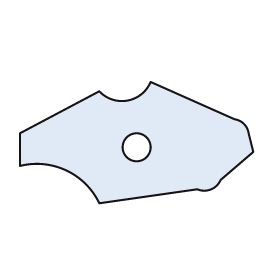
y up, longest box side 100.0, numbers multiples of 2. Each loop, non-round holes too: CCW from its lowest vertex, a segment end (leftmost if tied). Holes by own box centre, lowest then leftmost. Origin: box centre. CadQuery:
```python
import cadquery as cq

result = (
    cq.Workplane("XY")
    .moveTo(-16.0, -26.0)
    .lineTo(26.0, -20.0)
    .threePointArc((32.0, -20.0), (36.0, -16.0))
    .lineTo(50.0, -4.0)
    .lineTo(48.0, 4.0)
    .threePointArc((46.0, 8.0), (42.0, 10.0))
    .lineTo(6.0, 26.0)
    .threePointArc((-4.0, 18.0), (-16.0, 22.0))
    .lineTo(-50.0, 4.0)
    .lineTo(-50.0, -10.0)
    .threePointArc((-30.0, -12.0), (-16.0, -26.0))
    .close()
    .moveTo(0.0, -2.0)
    .circle(6.0)
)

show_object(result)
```